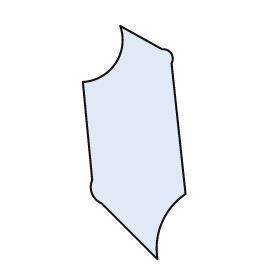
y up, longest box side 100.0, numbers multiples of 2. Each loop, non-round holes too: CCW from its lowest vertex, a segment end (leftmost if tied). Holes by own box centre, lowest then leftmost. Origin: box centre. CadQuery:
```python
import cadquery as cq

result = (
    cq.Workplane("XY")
    .moveTo(10.0, -50.0)
    .threePointArc((12.0, -34.0), (22.0, -22.0))
    .lineTo(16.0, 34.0)
    .threePointArc((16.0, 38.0), (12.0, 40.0))
    .lineTo(-6.0, 50.0)
    .threePointArc((-8.0, 34.0), (-22.0, 26.0))
    .lineTo(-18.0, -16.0)
    .threePointArc((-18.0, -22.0), (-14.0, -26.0))
    .close()
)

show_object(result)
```